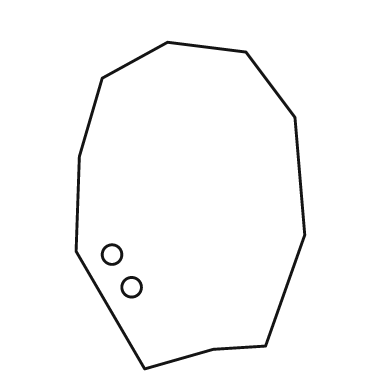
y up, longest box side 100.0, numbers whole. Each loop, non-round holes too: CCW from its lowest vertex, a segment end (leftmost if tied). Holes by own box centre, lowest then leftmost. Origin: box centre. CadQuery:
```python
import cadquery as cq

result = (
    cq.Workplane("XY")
    .moveTo(-14.0, -50.0)
    .lineTo(7.0, -44.0)
    .lineTo(23.0, -43.0)
    .lineTo(35.0, -9.0)
    .lineTo(32.0, 27.0)
    .lineTo(17.0, 47.0)
    .lineTo(-7.0, 50.0)
    .lineTo(-27.0, 39.0)
    .lineTo(-34.0, 15.0)
    .lineTo(-35.0, -14.0)
    .close()
    .moveTo(-18.0, -25.0)
    .circle(3.0)
    .moveTo(-24.0, -15.0)
    .circle(3.0)
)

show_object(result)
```